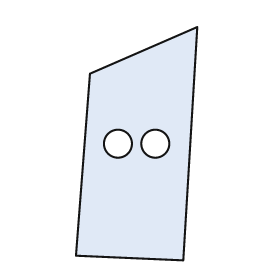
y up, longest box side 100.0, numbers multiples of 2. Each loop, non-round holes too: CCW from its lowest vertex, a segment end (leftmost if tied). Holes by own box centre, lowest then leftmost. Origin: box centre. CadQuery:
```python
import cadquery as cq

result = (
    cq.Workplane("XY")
    .moveTo(20.0, -50.0)
    .lineTo(26.0, 50.0)
    .lineTo(-20.0, 30.0)
    .lineTo(-26.0, -48.0)
    .close()
    .moveTo(-8.0, 0.0)
    .circle(6.0)
    .moveTo(8.0, 0.0)
    .circle(6.0)
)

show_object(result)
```